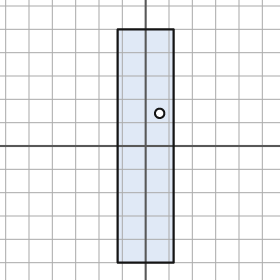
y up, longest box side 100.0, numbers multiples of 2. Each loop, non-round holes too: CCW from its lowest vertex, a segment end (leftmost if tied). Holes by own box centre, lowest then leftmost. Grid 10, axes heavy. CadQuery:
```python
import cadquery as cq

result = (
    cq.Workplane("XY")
    .moveTo(-12.0, -50.0)
    .lineTo(12.0, -50.0)
    .lineTo(12.0, 50.0)
    .lineTo(-12.0, 50.0)
    .close()
    .moveTo(6.0, 14.0)
    .circle(2.0)
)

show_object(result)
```